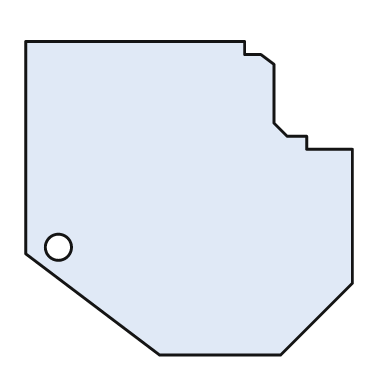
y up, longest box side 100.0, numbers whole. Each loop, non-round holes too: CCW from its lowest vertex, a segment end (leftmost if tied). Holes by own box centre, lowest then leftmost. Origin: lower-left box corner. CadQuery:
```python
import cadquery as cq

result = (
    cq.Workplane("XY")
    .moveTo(41.0, 0.0)
    .lineTo(78.0, 0.0)
    .lineTo(100.0, 22.0)
    .lineTo(100.0, 63.0)
    .lineTo(86.0, 63.0)
    .lineTo(86.0, 67.0)
    .lineTo(80.0, 67.0)
    .lineTo(76.0, 71.0)
    .lineTo(76.0, 89.0)
    .lineTo(72.0, 92.0)
    .lineTo(67.0, 92.0)
    .lineTo(67.0, 96.0)
    .lineTo(0.0, 96.0)
    .lineTo(0.0, 31.0)
    .close()
    .moveTo(10.0, 33.0)
    .circle(4.0)
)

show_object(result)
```